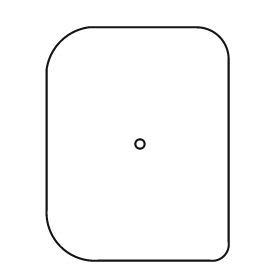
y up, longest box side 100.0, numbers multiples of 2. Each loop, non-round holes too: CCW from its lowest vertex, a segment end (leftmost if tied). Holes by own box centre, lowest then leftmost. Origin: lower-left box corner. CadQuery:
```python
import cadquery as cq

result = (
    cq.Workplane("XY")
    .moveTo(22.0, 0.0)
    .lineTo(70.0, 0.0)
    .threePointArc((76.0, 2.0), (78.0, 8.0))
    .lineTo(78.0, 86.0)
    .threePointArc((74.0, 96.0), (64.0, 100.0))
    .lineTo(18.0, 100.0)
    .threePointArc((6.0, 94.0), (0.0, 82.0))
    .lineTo(0.0, 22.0)
    .threePointArc((6.0, 6.0), (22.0, 0.0))
    .close()
    .moveTo(40.0, 50.0)
    .circle(2.0)
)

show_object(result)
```